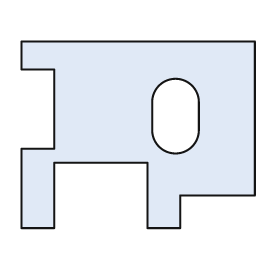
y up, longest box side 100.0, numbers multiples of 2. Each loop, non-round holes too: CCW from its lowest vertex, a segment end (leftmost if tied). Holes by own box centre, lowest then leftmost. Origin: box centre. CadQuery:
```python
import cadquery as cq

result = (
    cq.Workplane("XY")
    .moveTo(-50.0, -40.0)
    .lineTo(-36.0, -40.0)
    .lineTo(-36.0, -12.0)
    .lineTo(4.0, -12.0)
    .lineTo(4.0, -40.0)
    .lineTo(18.0, -40.0)
    .lineTo(18.0, -26.0)
    .lineTo(50.0, -26.0)
    .lineTo(50.0, 40.0)
    .lineTo(-50.0, 40.0)
    .lineTo(-50.0, 28.0)
    .lineTo(-36.0, 28.0)
    .lineTo(-36.0, -6.0)
    .lineTo(-50.0, -6.0)
    .close()
    .moveTo(6.0, 2.0)
    .threePointArc((16.0, -8.0), (26.0, 2.0))
    .lineTo(26.0, 14.0)
    .threePointArc((16.0, 24.0), (6.0, 14.0))
    .close()
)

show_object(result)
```